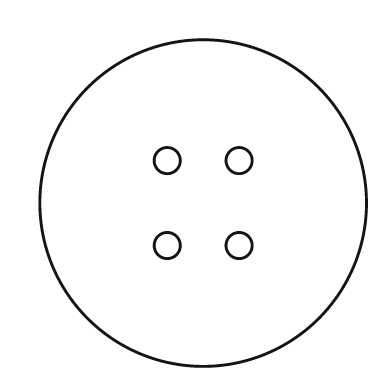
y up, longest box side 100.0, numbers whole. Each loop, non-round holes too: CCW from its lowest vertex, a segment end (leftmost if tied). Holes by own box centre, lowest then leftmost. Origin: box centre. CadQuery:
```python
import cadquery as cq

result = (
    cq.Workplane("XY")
    .moveTo(0.0, 0.0)
    .circle(50.0)
    .moveTo(-11.0, -13.0)
    .circle(4.0)
    .moveTo(11.0, -13.0)
    .circle(4.0)
    .moveTo(-11.0, 13.0)
    .circle(4.0)
    .moveTo(11.0, 13.0)
    .circle(4.0)
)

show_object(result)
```